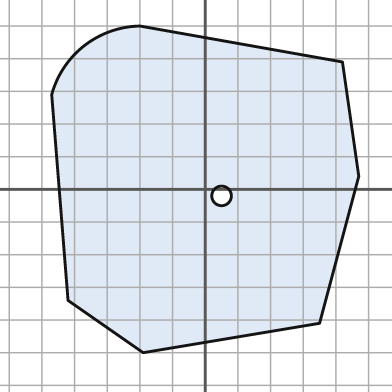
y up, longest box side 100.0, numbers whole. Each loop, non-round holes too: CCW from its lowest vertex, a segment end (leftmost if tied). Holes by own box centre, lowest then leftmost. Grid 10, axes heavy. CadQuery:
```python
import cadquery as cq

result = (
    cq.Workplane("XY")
    .moveTo(-19.0, -50.0)
    .lineTo(35.0, -41.0)
    .lineTo(47.0, 4.0)
    .lineTo(42.0, 39.0)
    .lineTo(-20.0, 50.0)
    .threePointArc((-37.0, 44.0), (-47.0, 29.0))
    .lineTo(-42.0, -34.0)
    .close()
    .moveTo(5.0, -2.0)
    .circle(3.0)
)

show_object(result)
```